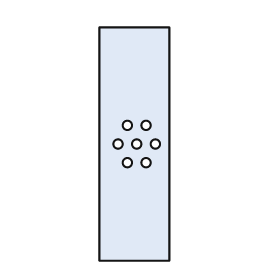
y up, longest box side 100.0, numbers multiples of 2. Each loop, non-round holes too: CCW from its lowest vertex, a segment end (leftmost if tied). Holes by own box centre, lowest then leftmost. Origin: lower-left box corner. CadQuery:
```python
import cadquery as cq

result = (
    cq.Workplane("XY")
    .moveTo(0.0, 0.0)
    .lineTo(30.0, 0.0)
    .lineTo(30.0, 100.0)
    .lineTo(0.0, 100.0)
    .close()
    .moveTo(12.0, 42.0)
    .circle(2.0)
    .moveTo(20.0, 42.0)
    .circle(2.0)
    .moveTo(8.0, 50.0)
    .circle(2.0)
    .moveTo(16.0, 50.0)
    .circle(2.0)
    .moveTo(24.0, 50.0)
    .circle(2.0)
    .moveTo(12.0, 58.0)
    .circle(2.0)
    .moveTo(20.0, 58.0)
    .circle(2.0)
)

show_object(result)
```